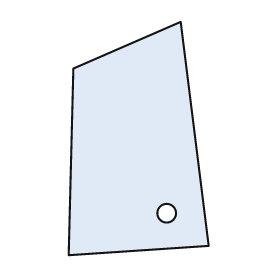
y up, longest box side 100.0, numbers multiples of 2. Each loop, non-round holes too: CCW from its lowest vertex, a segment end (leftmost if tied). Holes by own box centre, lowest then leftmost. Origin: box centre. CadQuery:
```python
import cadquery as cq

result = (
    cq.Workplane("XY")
    .moveTo(-30.0, -50.0)
    .lineTo(30.0, -46.0)
    .lineTo(18.0, 50.0)
    .lineTo(-28.0, 30.0)
    .close()
    .moveTo(12.0, -32.0)
    .circle(4.0)
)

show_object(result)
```